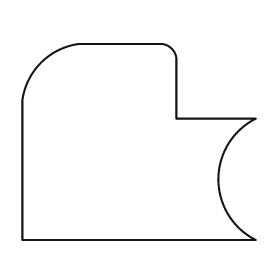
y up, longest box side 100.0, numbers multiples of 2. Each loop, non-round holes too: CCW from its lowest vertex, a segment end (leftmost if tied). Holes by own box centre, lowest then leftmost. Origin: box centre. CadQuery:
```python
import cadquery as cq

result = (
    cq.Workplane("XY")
    .moveTo(-50.0, -42.0)
    .lineTo(50.0, -42.0)
    .threePointArc((34.0, -16.0), (50.0, 10.0))
    .lineTo(16.0, 10.0)
    .lineTo(16.0, 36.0)
    .threePointArc((14.0, 40.0), (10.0, 42.0))
    .lineTo(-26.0, 42.0)
    .threePointArc((-42.0, 34.0), (-50.0, 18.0))
    .close()
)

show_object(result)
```